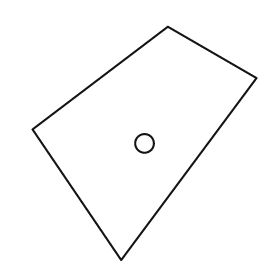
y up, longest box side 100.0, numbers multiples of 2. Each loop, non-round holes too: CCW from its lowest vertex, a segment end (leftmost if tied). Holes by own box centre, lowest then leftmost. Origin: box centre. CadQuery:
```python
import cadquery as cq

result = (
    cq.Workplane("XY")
    .moveTo(-10.0, -50.0)
    .lineTo(48.0, 28.0)
    .lineTo(10.0, 50.0)
    .lineTo(-48.0, 6.0)
    .close()
    .moveTo(0.0, 0.0)
    .circle(4.0)
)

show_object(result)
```